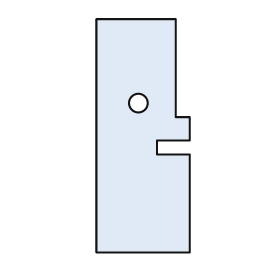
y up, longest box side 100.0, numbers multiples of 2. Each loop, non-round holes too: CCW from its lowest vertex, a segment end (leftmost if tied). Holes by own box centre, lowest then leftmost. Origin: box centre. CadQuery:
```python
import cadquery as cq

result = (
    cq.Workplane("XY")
    .moveTo(-20.0, -50.0)
    .lineTo(20.0, -50.0)
    .lineTo(20.0, -8.0)
    .lineTo(6.0, -8.0)
    .lineTo(6.0, -2.0)
    .lineTo(20.0, -2.0)
    .lineTo(20.0, 8.0)
    .lineTo(14.0, 8.0)
    .lineTo(14.0, 50.0)
    .lineTo(-20.0, 50.0)
    .close()
    .moveTo(-2.0, 14.0)
    .circle(4.0)
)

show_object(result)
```